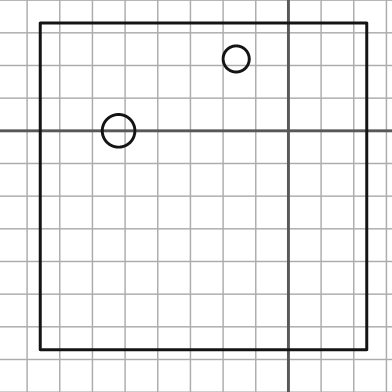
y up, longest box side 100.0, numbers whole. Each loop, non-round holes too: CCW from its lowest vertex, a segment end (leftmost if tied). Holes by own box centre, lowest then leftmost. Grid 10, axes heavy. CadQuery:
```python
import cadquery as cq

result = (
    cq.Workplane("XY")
    .moveTo(-76.0, -67.0)
    .lineTo(24.0, -67.0)
    .lineTo(24.0, 33.0)
    .lineTo(-76.0, 33.0)
    .close()
    .moveTo(-52.0, 0.0)
    .circle(5.0)
    .moveTo(-16.0, 22.0)
    .circle(4.0)
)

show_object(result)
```